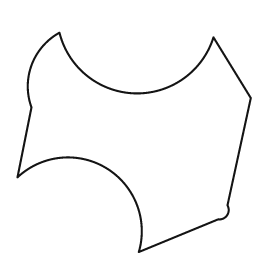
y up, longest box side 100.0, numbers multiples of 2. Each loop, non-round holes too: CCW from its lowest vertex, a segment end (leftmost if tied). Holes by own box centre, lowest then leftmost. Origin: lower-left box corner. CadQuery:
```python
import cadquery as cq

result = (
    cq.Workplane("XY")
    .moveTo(52.0, 0.0)
    .lineTo(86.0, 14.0)
    .threePointArc((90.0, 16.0), (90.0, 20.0))
    .lineTo(100.0, 66.0)
    .lineTo(84.0, 92.0)
    .threePointArc((50.0, 68.0), (18.0, 94.0))
    .threePointArc((6.0, 80.0), (6.0, 62.0))
    .lineTo(0.0, 32.0)
    .threePointArc((38.0, 36.0), (52.0, 0.0))
    .close()
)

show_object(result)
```